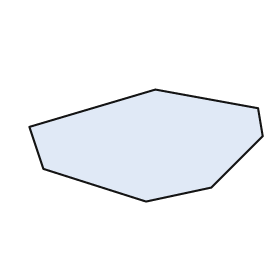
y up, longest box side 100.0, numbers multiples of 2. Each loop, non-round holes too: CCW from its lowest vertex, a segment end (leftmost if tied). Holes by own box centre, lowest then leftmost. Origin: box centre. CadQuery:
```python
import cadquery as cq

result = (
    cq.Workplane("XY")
    .moveTo(0.0, -24.0)
    .lineTo(28.0, -18.0)
    .lineTo(50.0, 4.0)
    .lineTo(48.0, 16.0)
    .lineTo(4.0, 24.0)
    .lineTo(-50.0, 8.0)
    .lineTo(-44.0, -10.0)
    .close()
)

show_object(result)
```